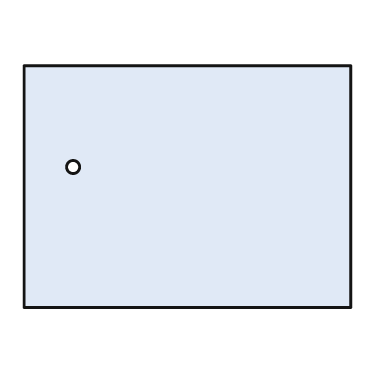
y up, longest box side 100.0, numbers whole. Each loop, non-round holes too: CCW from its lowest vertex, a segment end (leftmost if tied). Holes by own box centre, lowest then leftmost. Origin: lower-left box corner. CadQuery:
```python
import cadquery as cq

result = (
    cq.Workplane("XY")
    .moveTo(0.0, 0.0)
    .lineTo(100.0, 0.0)
    .lineTo(100.0, 74.0)
    .lineTo(0.0, 74.0)
    .close()
    .moveTo(15.0, 43.0)
    .circle(2.0)
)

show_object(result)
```